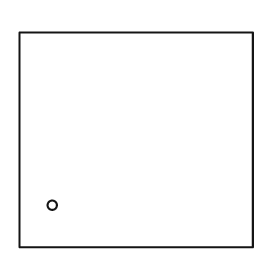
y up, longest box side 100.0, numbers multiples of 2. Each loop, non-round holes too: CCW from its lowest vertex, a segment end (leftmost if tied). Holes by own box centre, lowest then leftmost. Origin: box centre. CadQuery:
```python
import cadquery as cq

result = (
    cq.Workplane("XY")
    .moveTo(-50.0, -46.0)
    .lineTo(50.0, -46.0)
    .lineTo(50.0, 46.0)
    .lineTo(-50.0, 46.0)
    .close()
    .moveTo(-36.0, -28.0)
    .circle(2.0)
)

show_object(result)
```